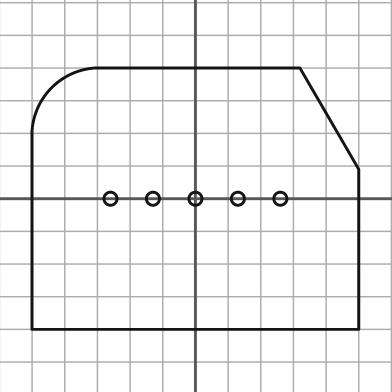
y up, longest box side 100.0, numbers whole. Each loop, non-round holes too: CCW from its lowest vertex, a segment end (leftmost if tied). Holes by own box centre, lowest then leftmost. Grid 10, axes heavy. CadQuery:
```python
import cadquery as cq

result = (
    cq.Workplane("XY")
    .moveTo(-50.0, -40.0)
    .lineTo(50.0, -40.0)
    .lineTo(50.0, 9.0)
    .lineTo(32.0, 40.0)
    .lineTo(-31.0, 40.0)
    .threePointArc((-44.0, 34.0), (-50.0, 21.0))
    .close()
    .moveTo(-26.0, 0.0)
    .circle(2.0)
    .moveTo(-13.0, 0.0)
    .circle(2.0)
    .moveTo(0.0, 0.0)
    .circle(2.0)
    .moveTo(13.0, 0.0)
    .circle(2.0)
    .moveTo(26.0, 0.0)
    .circle(2.0)
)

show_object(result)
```